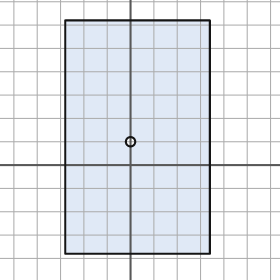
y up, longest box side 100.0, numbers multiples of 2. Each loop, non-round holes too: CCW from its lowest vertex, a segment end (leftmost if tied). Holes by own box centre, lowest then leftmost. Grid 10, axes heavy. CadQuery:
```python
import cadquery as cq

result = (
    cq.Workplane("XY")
    .moveTo(-28.0, -38.0)
    .lineTo(34.0, -38.0)
    .lineTo(34.0, 62.0)
    .lineTo(-28.0, 62.0)
    .close()
    .moveTo(0.0, 10.0)
    .circle(2.0)
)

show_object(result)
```